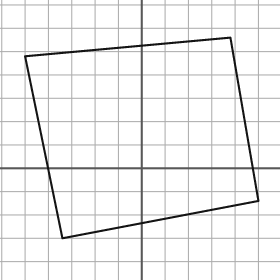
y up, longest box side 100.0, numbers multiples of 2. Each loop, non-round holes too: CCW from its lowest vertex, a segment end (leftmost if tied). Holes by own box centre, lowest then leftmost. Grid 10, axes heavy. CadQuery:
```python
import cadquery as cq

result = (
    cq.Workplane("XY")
    .moveTo(-34.0, -30.0)
    .lineTo(50.0, -14.0)
    .lineTo(38.0, 56.0)
    .lineTo(-50.0, 48.0)
    .close()
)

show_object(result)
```